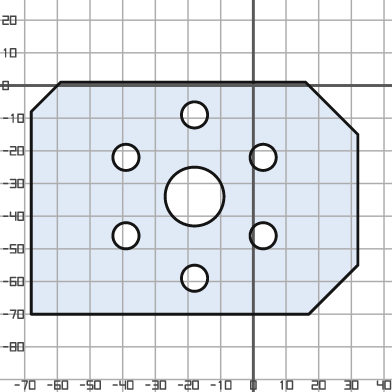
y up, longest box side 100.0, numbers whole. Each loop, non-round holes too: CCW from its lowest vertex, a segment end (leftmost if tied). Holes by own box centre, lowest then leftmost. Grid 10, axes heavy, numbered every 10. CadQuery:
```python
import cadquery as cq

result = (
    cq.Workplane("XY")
    .moveTo(-68.0, -70.0)
    .lineTo(17.0, -70.0)
    .lineTo(32.0, -55.0)
    .lineTo(32.0, -15.0)
    .lineTo(16.0, 1.0)
    .lineTo(-59.0, 1.0)
    .lineTo(-68.0, -8.0)
    .close()
    .moveTo(-18.0, -59.0)
    .circle(4.0)
    .moveTo(-39.0, -46.0)
    .circle(4.0)
    .moveTo(3.0, -46.0)
    .circle(4.0)
    .moveTo(-18.0, -34.0)
    .circle(9.0)
    .moveTo(-39.0, -22.0)
    .circle(4.0)
    .moveTo(3.0, -22.0)
    .circle(4.0)
    .moveTo(-18.0, -9.0)
    .circle(4.0)
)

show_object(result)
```